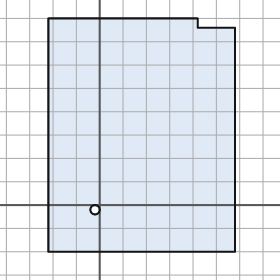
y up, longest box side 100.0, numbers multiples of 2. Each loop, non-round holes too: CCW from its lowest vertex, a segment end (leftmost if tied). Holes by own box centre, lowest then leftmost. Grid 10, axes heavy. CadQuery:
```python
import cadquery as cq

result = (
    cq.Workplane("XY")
    .moveTo(-22.0, -20.0)
    .lineTo(58.0, -20.0)
    .lineTo(58.0, 76.0)
    .lineTo(42.0, 76.0)
    .lineTo(42.0, 80.0)
    .lineTo(-22.0, 80.0)
    .close()
    .moveTo(-2.0, -2.0)
    .circle(2.0)
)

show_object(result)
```